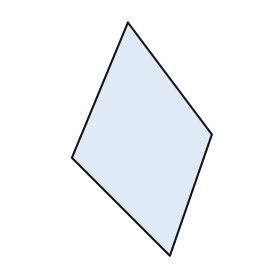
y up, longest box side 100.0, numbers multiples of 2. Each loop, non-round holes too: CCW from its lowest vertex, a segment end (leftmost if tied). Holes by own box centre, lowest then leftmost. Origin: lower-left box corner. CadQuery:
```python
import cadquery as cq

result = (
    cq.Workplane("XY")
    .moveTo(42.0, 0.0)
    .lineTo(60.0, 52.0)
    .lineTo(24.0, 100.0)
    .lineTo(0.0, 42.0)
    .close()
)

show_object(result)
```